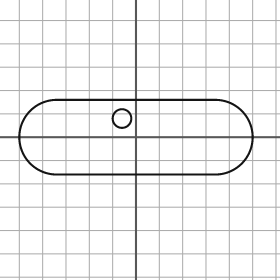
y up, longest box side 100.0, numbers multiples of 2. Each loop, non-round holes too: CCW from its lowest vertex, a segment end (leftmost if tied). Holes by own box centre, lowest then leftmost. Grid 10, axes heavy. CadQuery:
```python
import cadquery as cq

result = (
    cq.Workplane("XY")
    .moveTo(-34.0, -16.0)
    .lineTo(34.0, -16.0)
    .threePointArc((50.0, 0.0), (34.0, 16.0))
    .lineTo(-34.0, 16.0)
    .threePointArc((-50.0, 0.0), (-34.0, -16.0))
    .close()
    .moveTo(-6.0, 8.0)
    .circle(4.0)
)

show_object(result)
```